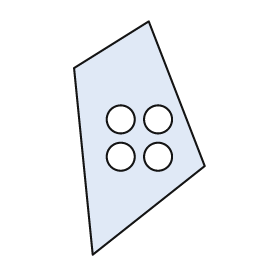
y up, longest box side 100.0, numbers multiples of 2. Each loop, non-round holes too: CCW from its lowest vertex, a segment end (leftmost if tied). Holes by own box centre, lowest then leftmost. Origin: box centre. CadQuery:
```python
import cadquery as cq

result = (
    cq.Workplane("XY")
    .moveTo(-20.0, -50.0)
    .lineTo(28.0, -12.0)
    .lineTo(4.0, 50.0)
    .lineTo(-28.0, 30.0)
    .close()
    .moveTo(-8.0, -8.0)
    .circle(6.0)
    .moveTo(8.0, -8.0)
    .circle(6.0)
    .moveTo(-8.0, 8.0)
    .circle(6.0)
    .moveTo(8.0, 8.0)
    .circle(6.0)
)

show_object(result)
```